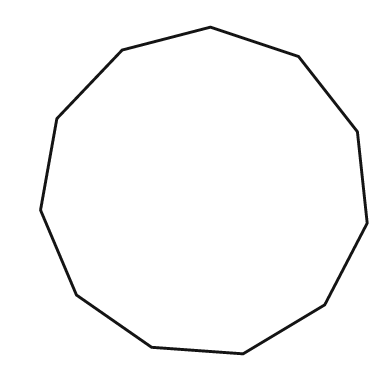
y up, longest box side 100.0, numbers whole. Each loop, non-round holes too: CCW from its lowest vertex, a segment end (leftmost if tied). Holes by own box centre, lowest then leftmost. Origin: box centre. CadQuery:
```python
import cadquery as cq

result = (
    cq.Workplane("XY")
    .moveTo(12.0, -50.0)
    .lineTo(37.0, -35.0)
    .lineTo(50.0, -10.0)
    .lineTo(47.0, 18.0)
    .lineTo(29.0, 41.0)
    .lineTo(2.0, 50.0)
    .lineTo(-25.0, 43.0)
    .lineTo(-45.0, 22.0)
    .lineTo(-50.0, -6.0)
    .lineTo(-39.0, -32.0)
    .lineTo(-16.0, -48.0)
    .close()
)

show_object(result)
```